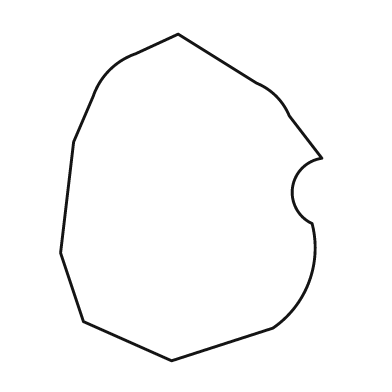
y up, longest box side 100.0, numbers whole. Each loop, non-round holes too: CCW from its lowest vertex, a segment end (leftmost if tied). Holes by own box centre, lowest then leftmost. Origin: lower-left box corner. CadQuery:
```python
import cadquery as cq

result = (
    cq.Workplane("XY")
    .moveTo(34.0, 0.0)
    .lineTo(65.0, 10.0)
    .threePointArc((76.0, 24.0), (77.0, 42.0))
    .threePointArc((71.0, 53.0), (80.0, 62.0))
    .lineTo(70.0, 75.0)
    .threePointArc((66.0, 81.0), (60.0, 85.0))
    .lineTo(36.0, 100.0)
    .lineTo(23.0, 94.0)
    .threePointArc((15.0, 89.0), (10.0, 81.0))
    .lineTo(4.0, 67.0)
    .lineTo(0.0, 33.0)
    .lineTo(7.0, 12.0)
    .close()
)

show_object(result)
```